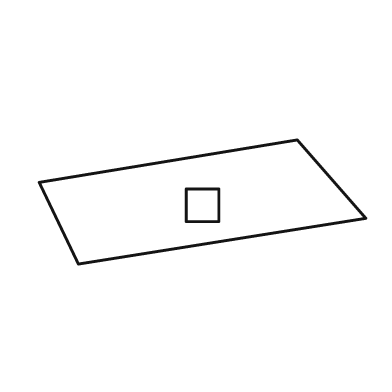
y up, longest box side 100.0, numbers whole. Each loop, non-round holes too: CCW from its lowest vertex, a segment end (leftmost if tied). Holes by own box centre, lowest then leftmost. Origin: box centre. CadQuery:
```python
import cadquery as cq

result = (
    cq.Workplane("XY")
    .moveTo(-38.0, -19.0)
    .lineTo(50.0, -5.0)
    .lineTo(29.0, 19.0)
    .lineTo(-50.0, 6.0)
    .close()
    .moveTo(-5.0, -6.0)
    .lineTo(5.0, -6.0)
    .lineTo(5.0, 4.0)
    .lineTo(-5.0, 4.0)
    .close()
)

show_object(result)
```